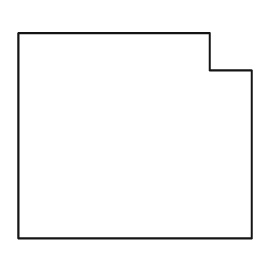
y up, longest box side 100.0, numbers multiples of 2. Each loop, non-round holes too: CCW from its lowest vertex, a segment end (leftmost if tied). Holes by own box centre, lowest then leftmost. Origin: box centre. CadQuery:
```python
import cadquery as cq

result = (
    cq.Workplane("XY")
    .moveTo(-50.0, -44.0)
    .lineTo(50.0, -44.0)
    .lineTo(50.0, 28.0)
    .lineTo(32.0, 28.0)
    .lineTo(32.0, 44.0)
    .lineTo(-50.0, 44.0)
    .close()
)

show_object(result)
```